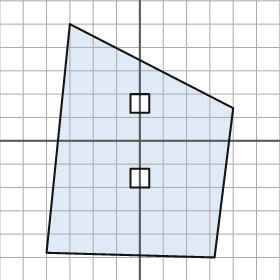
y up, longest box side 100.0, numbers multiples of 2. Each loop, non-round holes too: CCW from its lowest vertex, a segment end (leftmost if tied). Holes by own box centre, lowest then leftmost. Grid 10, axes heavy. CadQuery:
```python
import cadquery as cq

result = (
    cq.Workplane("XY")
    .moveTo(32.0, -50.0)
    .lineTo(40.0, 14.0)
    .lineTo(-30.0, 50.0)
    .lineTo(-40.0, -48.0)
    .close()
    .moveTo(-4.0, -20.0)
    .lineTo(4.0, -20.0)
    .lineTo(4.0, -12.0)
    .lineTo(-4.0, -12.0)
    .close()
    .moveTo(-4.0, 12.0)
    .lineTo(4.0, 12.0)
    .lineTo(4.0, 20.0)
    .lineTo(-4.0, 20.0)
    .close()
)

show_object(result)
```